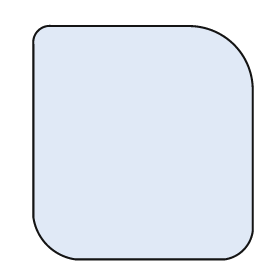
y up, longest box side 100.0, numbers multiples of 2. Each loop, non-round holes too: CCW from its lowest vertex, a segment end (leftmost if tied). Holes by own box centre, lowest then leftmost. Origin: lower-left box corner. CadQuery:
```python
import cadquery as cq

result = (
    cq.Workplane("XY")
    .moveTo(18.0, 0.0)
    .lineTo(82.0, 0.0)
    .threePointArc((90.0, 4.0), (94.0, 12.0))
    .lineTo(94.0, 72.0)
    .threePointArc((86.0, 92.0), (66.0, 100.0))
    .lineTo(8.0, 100.0)
    .threePointArc((2.0, 98.0), (0.0, 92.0))
    .lineTo(0.0, 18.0)
    .threePointArc((6.0, 6.0), (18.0, 0.0))
    .close()
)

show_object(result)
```